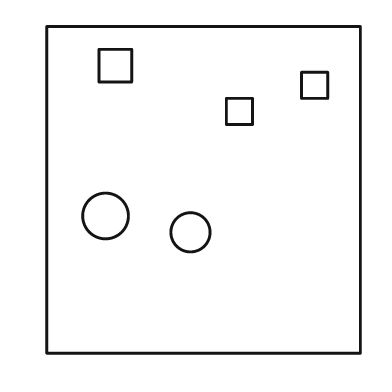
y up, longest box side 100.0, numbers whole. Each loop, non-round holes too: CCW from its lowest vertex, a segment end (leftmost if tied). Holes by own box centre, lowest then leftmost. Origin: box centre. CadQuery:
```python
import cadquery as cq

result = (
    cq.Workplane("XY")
    .moveTo(-48.0, -50.0)
    .lineTo(48.0, -50.0)
    .lineTo(48.0, 50.0)
    .lineTo(-48.0, 50.0)
    .close()
    .moveTo(-4.0, -13.0)
    .circle(6.0)
    .moveTo(-30.0, -8.0)
    .circle(7.0)
    .moveTo(7.0, 20.0)
    .lineTo(15.0, 20.0)
    .lineTo(15.0, 28.0)
    .lineTo(7.0, 28.0)
    .close()
    .moveTo(30.0, 28.0)
    .lineTo(38.0, 28.0)
    .lineTo(38.0, 36.0)
    .lineTo(30.0, 36.0)
    .close()
    .moveTo(-32.0, 33.0)
    .lineTo(-22.0, 33.0)
    .lineTo(-22.0, 43.0)
    .lineTo(-32.0, 43.0)
    .close()
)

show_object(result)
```